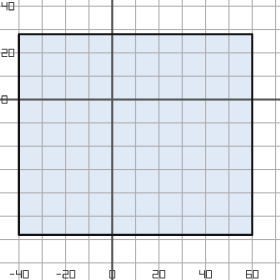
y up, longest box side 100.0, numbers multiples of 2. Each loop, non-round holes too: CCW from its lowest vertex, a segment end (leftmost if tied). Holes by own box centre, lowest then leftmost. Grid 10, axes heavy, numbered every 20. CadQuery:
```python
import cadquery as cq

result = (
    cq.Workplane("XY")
    .moveTo(-40.0, -58.0)
    .lineTo(60.0, -58.0)
    .lineTo(60.0, 28.0)
    .lineTo(-40.0, 28.0)
    .close()
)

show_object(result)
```